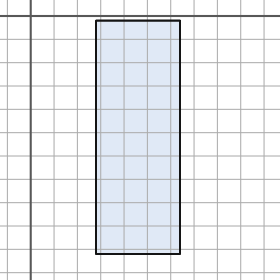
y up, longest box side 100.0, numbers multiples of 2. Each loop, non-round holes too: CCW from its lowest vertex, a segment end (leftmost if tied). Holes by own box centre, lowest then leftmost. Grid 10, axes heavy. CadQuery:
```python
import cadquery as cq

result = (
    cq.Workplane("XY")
    .moveTo(28.0, -102.0)
    .lineTo(64.0, -102.0)
    .lineTo(64.0, -2.0)
    .lineTo(28.0, -2.0)
    .close()
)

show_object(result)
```